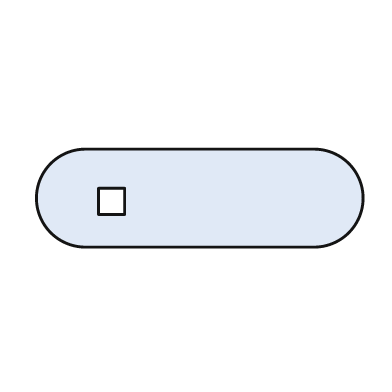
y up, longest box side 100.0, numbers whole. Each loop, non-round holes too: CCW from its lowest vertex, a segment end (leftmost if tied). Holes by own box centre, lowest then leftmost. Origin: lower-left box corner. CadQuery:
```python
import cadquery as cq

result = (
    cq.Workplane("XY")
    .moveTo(15.0, 0.0)
    .lineTo(85.0, 0.0)
    .threePointArc((100.0, 15.0), (85.0, 30.0))
    .lineTo(15.0, 30.0)
    .threePointArc((0.0, 15.0), (15.0, 0.0))
    .close()
    .moveTo(19.0, 10.0)
    .lineTo(27.0, 10.0)
    .lineTo(27.0, 18.0)
    .lineTo(19.0, 18.0)
    .close()
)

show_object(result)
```